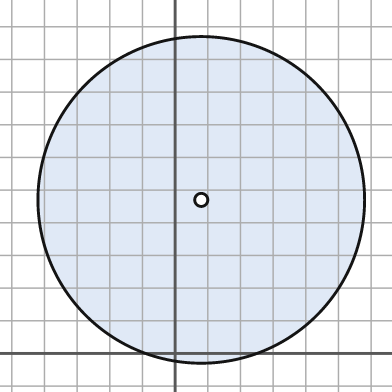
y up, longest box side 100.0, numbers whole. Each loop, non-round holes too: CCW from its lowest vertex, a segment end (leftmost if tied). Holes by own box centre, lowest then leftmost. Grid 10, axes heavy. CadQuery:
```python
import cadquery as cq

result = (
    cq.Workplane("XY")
    .moveTo(8.0, 47.0)
    .circle(50.0)
    .moveTo(8.0, 47.0)
    .circle(2.0)
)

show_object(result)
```